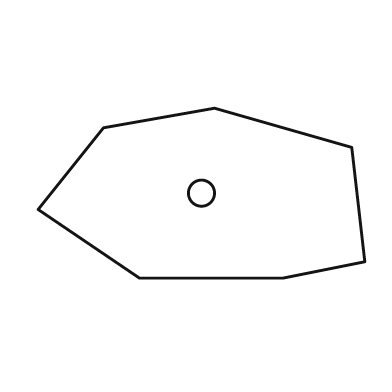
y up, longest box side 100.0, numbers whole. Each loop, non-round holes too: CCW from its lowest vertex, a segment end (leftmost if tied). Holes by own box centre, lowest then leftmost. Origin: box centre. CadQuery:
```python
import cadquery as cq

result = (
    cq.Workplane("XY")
    .moveTo(-19.0, -26.0)
    .lineTo(25.0, -26.0)
    .lineTo(50.0, -21.0)
    .lineTo(46.0, 14.0)
    .lineTo(4.0, 26.0)
    .lineTo(-30.0, 20.0)
    .lineTo(-50.0, -5.0)
    .close()
    .moveTo(0.0, 0.0)
    .circle(4.0)
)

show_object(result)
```